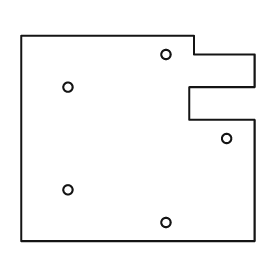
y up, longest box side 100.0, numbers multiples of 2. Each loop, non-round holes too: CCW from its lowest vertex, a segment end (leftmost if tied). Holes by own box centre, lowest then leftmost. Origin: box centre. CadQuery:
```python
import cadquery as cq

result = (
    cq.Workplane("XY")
    .moveTo(-50.0, -44.0)
    .lineTo(50.0, -44.0)
    .lineTo(50.0, 8.0)
    .lineTo(22.0, 8.0)
    .lineTo(22.0, 22.0)
    .lineTo(50.0, 22.0)
    .lineTo(50.0, 36.0)
    .lineTo(24.0, 36.0)
    .lineTo(24.0, 44.0)
    .lineTo(-50.0, 44.0)
    .close()
    .moveTo(12.0, -36.0)
    .circle(2.0)
    .moveTo(-30.0, -22.0)
    .circle(2.0)
    .moveTo(38.0, 0.0)
    .circle(2.0)
    .moveTo(-30.0, 22.0)
    .circle(2.0)
    .moveTo(12.0, 36.0)
    .circle(2.0)
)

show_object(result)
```